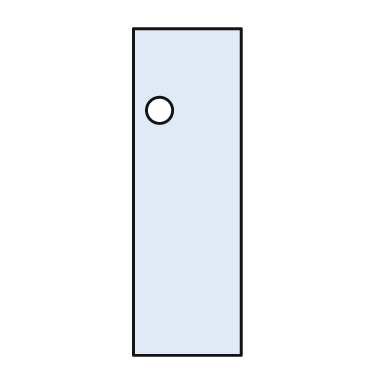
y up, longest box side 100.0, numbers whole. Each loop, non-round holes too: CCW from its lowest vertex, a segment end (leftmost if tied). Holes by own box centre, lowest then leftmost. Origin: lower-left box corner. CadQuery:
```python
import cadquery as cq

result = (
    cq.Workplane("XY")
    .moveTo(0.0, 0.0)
    .lineTo(33.0, 0.0)
    .lineTo(33.0, 100.0)
    .lineTo(0.0, 100.0)
    .close()
    .moveTo(8.0, 75.0)
    .circle(4.0)
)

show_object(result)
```